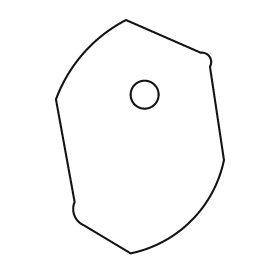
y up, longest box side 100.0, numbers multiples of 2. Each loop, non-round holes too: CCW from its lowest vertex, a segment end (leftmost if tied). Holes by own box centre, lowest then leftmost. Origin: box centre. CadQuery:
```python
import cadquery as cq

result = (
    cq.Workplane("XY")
    .moveTo(-4.0, -50.0)
    .threePointArc((22.0, -36.0), (36.0, -10.0))
    .lineTo(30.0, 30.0)
    .threePointArc((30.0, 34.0), (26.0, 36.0))
    .lineTo(-6.0, 50.0)
    .threePointArc((-24.0, 36.0), (-36.0, 16.0))
    .lineTo(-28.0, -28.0)
    .threePointArc((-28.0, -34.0), (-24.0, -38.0))
    .close()
    .moveTo(2.0, 18.0)
    .circle(6.0)
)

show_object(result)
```